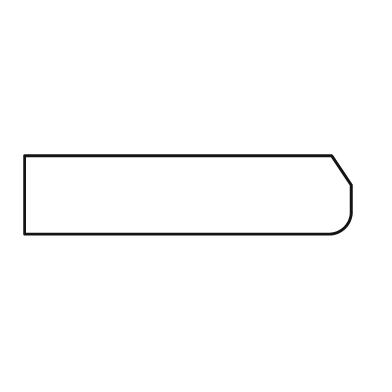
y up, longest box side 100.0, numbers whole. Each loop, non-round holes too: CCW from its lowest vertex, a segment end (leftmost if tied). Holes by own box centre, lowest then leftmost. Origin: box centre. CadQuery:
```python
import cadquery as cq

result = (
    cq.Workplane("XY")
    .moveTo(-50.0, -12.0)
    .lineTo(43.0, -12.0)
    .threePointArc((48.0, -10.0), (50.0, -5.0))
    .lineTo(50.0, 3.0)
    .lineTo(44.0, 12.0)
    .lineTo(-50.0, 12.0)
    .close()
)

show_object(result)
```